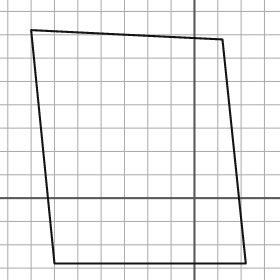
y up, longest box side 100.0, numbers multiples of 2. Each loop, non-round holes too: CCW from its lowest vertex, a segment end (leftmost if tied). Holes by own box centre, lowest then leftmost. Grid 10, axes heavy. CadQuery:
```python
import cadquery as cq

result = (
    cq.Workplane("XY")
    .moveTo(-60.0, -28.0)
    .lineTo(22.0, -28.0)
    .lineTo(12.0, 68.0)
    .lineTo(-70.0, 72.0)
    .close()
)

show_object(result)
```